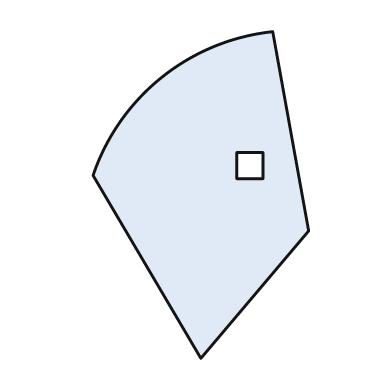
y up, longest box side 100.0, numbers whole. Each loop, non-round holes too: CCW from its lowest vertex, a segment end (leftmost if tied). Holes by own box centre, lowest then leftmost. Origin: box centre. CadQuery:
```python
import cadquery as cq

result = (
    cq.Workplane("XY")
    .moveTo(0.0, -50.0)
    .lineTo(33.0, -11.0)
    .lineTo(22.0, 50.0)
    .threePointArc((-12.0, 36.0), (-33.0, 6.0))
    .close()
    .moveTo(11.0, 5.0)
    .lineTo(19.0, 5.0)
    .lineTo(19.0, 13.0)
    .lineTo(11.0, 13.0)
    .close()
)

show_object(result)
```